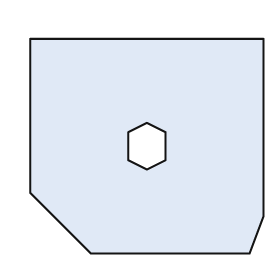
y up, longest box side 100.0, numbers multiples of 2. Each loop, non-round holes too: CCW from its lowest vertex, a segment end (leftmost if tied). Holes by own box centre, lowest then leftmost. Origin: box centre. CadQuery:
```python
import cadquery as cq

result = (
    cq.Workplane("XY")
    .moveTo(-24.0, -46.0)
    .lineTo(44.0, -46.0)
    .lineTo(50.0, -30.0)
    .lineTo(50.0, 46.0)
    .lineTo(-50.0, 46.0)
    .lineTo(-50.0, -20.0)
    .close()
    .moveTo(0.0, -10.0)
    .lineTo(8.0, -6.0)
    .lineTo(8.0, 6.0)
    .lineTo(0.0, 10.0)
    .lineTo(-8.0, 6.0)
    .lineTo(-8.0, -6.0)
    .close()
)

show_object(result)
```